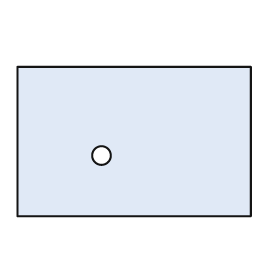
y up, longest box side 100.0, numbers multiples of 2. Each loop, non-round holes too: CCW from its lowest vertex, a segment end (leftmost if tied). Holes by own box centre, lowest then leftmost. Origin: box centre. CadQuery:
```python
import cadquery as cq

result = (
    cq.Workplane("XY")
    .moveTo(-50.0, -32.0)
    .lineTo(50.0, -32.0)
    .lineTo(50.0, 32.0)
    .lineTo(-50.0, 32.0)
    .close()
    .moveTo(-14.0, -6.0)
    .circle(4.0)
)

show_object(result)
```